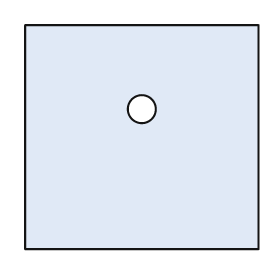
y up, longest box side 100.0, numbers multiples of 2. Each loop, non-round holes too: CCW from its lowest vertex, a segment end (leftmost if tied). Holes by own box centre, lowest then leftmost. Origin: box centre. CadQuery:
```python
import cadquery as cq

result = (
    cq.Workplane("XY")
    .moveTo(-50.0, -48.0)
    .lineTo(50.0, -48.0)
    .lineTo(50.0, 48.0)
    .lineTo(-50.0, 48.0)
    .close()
    .moveTo(0.0, 12.0)
    .circle(6.0)
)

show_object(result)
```